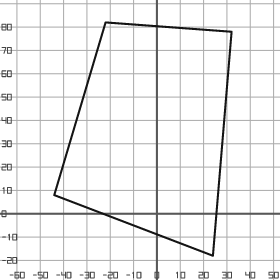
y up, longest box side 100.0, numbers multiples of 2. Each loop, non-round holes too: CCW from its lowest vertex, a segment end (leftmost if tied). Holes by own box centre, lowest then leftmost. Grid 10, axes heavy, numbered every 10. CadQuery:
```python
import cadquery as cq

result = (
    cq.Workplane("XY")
    .moveTo(24.0, -18.0)
    .lineTo(32.0, 78.0)
    .lineTo(-22.0, 82.0)
    .lineTo(-44.0, 8.0)
    .close()
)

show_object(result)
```